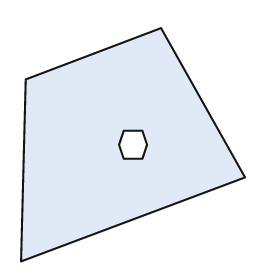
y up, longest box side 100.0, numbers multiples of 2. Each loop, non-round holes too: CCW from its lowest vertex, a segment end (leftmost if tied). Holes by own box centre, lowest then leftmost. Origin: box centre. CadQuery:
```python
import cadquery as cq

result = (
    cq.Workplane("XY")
    .moveTo(-48.0, -50.0)
    .lineTo(48.0, -14.0)
    .lineTo(12.0, 50.0)
    .lineTo(-46.0, 28.0)
    .close()
    .moveTo(-4.0, -6.0)
    .lineTo(4.0, -6.0)
    .lineTo(6.0, 0.0)
    .lineTo(4.0, 6.0)
    .lineTo(-4.0, 6.0)
    .lineTo(-6.0, 0.0)
    .close()
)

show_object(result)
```